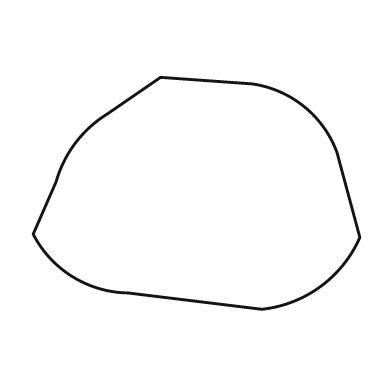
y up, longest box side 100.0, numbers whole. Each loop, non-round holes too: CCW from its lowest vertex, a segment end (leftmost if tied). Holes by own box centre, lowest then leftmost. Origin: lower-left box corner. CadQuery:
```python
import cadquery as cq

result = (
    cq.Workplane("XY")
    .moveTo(70.0, 0.0)
    .threePointArc((88.0, 7.0), (100.0, 22.0))
    .lineTo(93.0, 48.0)
    .threePointArc((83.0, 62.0), (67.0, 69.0))
    .lineTo(39.0, 71.0)
    .lineTo(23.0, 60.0)
    .threePointArc((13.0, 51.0), (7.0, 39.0))
    .lineTo(0.0, 23.0)
    .threePointArc((12.0, 10.0), (29.0, 5.0))
    .close()
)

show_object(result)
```